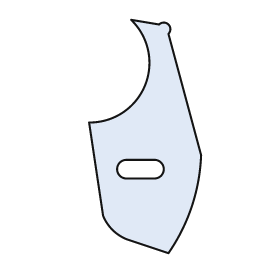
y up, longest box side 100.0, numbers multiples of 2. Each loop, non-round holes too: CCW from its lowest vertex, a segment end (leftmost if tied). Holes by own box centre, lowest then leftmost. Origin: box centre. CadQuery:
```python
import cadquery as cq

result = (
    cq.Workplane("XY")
    .moveTo(10.0, -50.0)
    .threePointArc((20.0, -30.0), (24.0, -8.0))
    .lineTo(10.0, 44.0)
    .threePointArc((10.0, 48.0), (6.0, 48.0))
    .lineTo(-6.0, 50.0)
    .threePointArc((0.0, 22.0), (-24.0, 6.0))
    .lineTo(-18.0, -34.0)
    .threePointArc((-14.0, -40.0), (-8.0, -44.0))
    .close()
    .moveTo(-8.0, -18.0)
    .lineTo(4.0, -18.0)
    .threePointArc((8.0, -14.0), (4.0, -10.0))
    .lineTo(-8.0, -10.0)
    .threePointArc((-12.0, -14.0), (-8.0, -18.0))
    .close()
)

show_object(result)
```